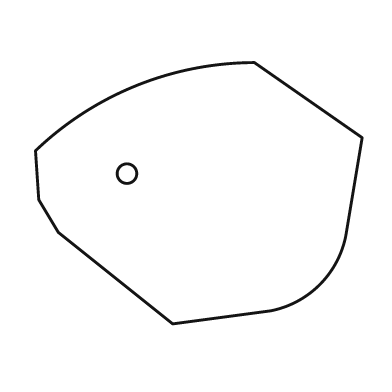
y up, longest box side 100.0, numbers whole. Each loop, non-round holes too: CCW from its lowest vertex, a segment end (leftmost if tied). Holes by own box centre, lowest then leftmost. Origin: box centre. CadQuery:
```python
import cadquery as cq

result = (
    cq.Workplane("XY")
    .moveTo(-8.0, -40.0)
    .lineTo(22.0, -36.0)
    .threePointArc((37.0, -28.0), (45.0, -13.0))
    .lineTo(50.0, 17.0)
    .lineTo(17.0, 40.0)
    .threePointArc((-19.0, 33.0), (-50.0, 13.0))
    .lineTo(-49.0, -2.0)
    .lineTo(-43.0, -12.0)
    .close()
    .moveTo(-22.0, 6.0)
    .circle(3.0)
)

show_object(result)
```